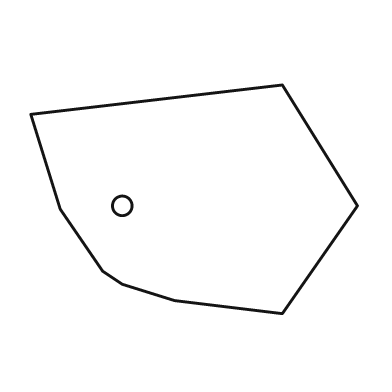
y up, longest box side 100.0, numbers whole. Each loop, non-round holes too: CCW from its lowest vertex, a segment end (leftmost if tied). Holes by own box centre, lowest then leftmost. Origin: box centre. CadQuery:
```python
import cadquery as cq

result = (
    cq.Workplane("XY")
    .moveTo(27.0, -35.0)
    .lineTo(50.0, -2.0)
    .lineTo(27.0, 35.0)
    .lineTo(-50.0, 26.0)
    .lineTo(-41.0, -3.0)
    .lineTo(-28.0, -22.0)
    .lineTo(-22.0, -26.0)
    .lineTo(-6.0, -31.0)
    .close()
    .moveTo(-22.0, -2.0)
    .circle(3.0)
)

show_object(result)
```